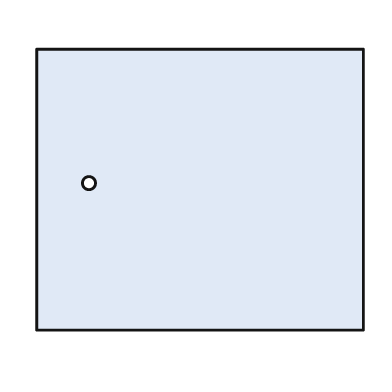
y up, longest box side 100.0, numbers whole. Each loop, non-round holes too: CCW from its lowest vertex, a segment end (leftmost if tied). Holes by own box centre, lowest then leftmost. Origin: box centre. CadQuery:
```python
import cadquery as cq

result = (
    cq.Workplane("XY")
    .moveTo(-50.0, -43.0)
    .lineTo(50.0, -43.0)
    .lineTo(50.0, 43.0)
    .lineTo(-50.0, 43.0)
    .close()
    .moveTo(-34.0, 2.0)
    .circle(2.0)
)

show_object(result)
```